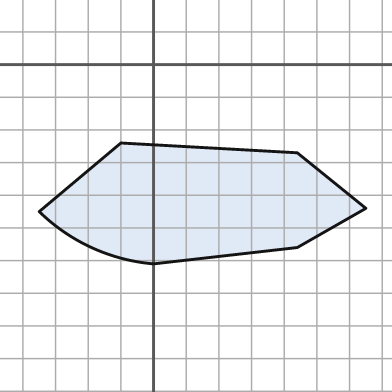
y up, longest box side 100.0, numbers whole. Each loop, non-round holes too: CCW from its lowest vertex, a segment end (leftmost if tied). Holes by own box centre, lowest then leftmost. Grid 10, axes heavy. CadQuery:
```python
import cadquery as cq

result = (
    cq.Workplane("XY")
    .moveTo(0.0, -61.0)
    .lineTo(44.0, -56.0)
    .lineTo(65.0, -44.0)
    .lineTo(44.0, -27.0)
    .lineTo(-10.0, -24.0)
    .lineTo(-35.0, -45.0)
    .threePointArc((-19.0, -56.0), (0.0, -61.0))
    .close()
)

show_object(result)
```